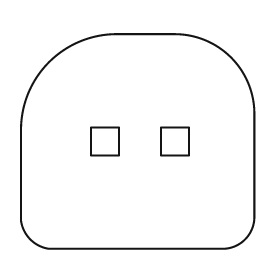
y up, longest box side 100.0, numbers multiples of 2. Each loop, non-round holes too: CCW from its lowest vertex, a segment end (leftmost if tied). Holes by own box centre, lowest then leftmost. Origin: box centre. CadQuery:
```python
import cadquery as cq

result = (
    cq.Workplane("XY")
    .moveTo(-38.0, -46.0)
    .lineTo(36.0, -46.0)
    .threePointArc((46.0, -42.0), (50.0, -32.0))
    .lineTo(50.0, 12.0)
    .threePointArc((40.0, 36.0), (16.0, 46.0))
    .lineTo(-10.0, 46.0)
    .threePointArc((-38.0, 34.0), (-50.0, 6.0))
    .lineTo(-50.0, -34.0)
    .threePointArc((-46.0, -42.0), (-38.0, -46.0))
    .close()
    .moveTo(-20.0, -6.0)
    .lineTo(-8.0, -6.0)
    .lineTo(-8.0, 6.0)
    .lineTo(-20.0, 6.0)
    .close()
    .moveTo(10.0, -6.0)
    .lineTo(22.0, -6.0)
    .lineTo(22.0, 6.0)
    .lineTo(10.0, 6.0)
    .close()
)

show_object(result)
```